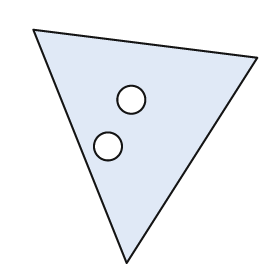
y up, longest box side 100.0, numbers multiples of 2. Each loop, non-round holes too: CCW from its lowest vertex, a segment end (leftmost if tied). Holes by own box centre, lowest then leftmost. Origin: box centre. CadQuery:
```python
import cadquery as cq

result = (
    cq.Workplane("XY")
    .moveTo(-8.0, -50.0)
    .lineTo(48.0, 38.0)
    .lineTo(-48.0, 50.0)
    .close()
    .moveTo(-16.0, 0.0)
    .circle(6.0)
    .moveTo(-6.0, 20.0)
    .circle(6.0)
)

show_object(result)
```